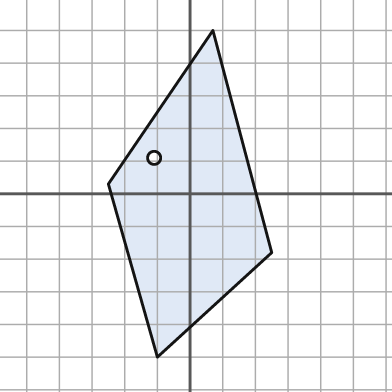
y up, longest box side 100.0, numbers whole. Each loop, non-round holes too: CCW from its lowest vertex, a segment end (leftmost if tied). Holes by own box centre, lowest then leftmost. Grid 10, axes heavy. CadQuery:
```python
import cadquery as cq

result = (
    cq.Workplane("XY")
    .moveTo(-10.0, -50.0)
    .lineTo(25.0, -18.0)
    .lineTo(7.0, 50.0)
    .lineTo(-25.0, 3.0)
    .close()
    .moveTo(-11.0, 11.0)
    .circle(2.0)
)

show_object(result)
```